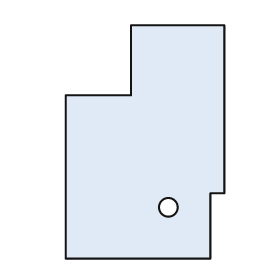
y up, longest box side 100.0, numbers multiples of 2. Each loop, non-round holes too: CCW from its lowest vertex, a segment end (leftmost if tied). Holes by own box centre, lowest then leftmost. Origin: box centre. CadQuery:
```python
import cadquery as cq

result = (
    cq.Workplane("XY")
    .moveTo(-34.0, -50.0)
    .lineTo(28.0, -50.0)
    .lineTo(28.0, -22.0)
    .lineTo(34.0, -22.0)
    .lineTo(34.0, 50.0)
    .lineTo(-6.0, 50.0)
    .lineTo(-6.0, 20.0)
    .lineTo(-34.0, 20.0)
    .close()
    .moveTo(10.0, -28.0)
    .circle(4.0)
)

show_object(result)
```